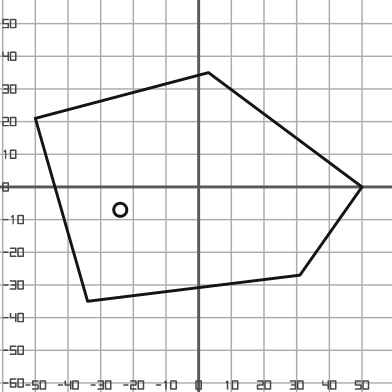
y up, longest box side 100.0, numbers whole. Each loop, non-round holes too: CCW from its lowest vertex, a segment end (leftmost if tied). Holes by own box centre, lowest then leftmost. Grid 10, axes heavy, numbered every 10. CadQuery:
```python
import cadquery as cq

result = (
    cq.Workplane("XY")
    .moveTo(-34.0, -35.0)
    .lineTo(31.0, -27.0)
    .lineTo(50.0, 0.0)
    .lineTo(3.0, 35.0)
    .lineTo(-50.0, 21.0)
    .close()
    .moveTo(-24.0, -7.0)
    .circle(2.0)
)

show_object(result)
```